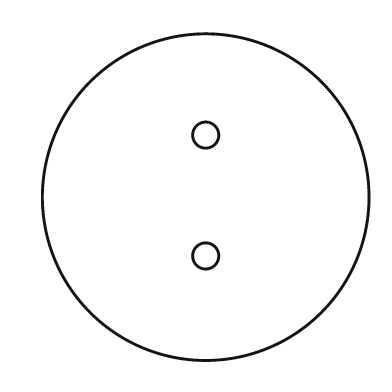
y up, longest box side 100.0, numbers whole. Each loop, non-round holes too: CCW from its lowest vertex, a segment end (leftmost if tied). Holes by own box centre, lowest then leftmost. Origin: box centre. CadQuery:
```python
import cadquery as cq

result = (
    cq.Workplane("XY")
    .moveTo(0.0, 0.0)
    .circle(50.0)
    .moveTo(0.0, -18.0)
    .circle(4.0)
    .moveTo(0.0, 19.0)
    .circle(4.0)
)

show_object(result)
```